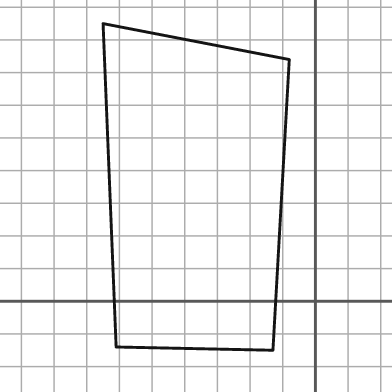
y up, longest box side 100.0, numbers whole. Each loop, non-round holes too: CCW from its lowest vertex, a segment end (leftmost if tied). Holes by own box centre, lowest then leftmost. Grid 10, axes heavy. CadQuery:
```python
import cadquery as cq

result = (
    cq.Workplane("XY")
    .moveTo(-13.0, -15.0)
    .lineTo(-8.0, 74.0)
    .lineTo(-65.0, 85.0)
    .lineTo(-61.0, -14.0)
    .close()
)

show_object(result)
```